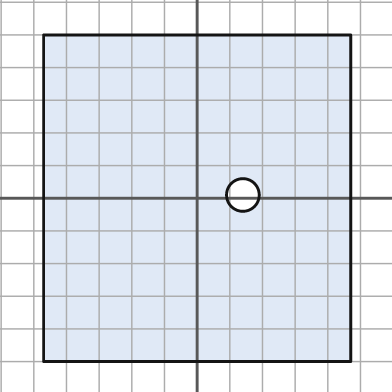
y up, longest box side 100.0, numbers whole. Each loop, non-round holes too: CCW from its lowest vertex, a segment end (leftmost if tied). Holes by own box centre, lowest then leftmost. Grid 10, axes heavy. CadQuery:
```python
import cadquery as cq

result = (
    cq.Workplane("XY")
    .moveTo(-47.0, -50.0)
    .lineTo(47.0, -50.0)
    .lineTo(47.0, 50.0)
    .lineTo(-47.0, 50.0)
    .close()
    .moveTo(14.0, 1.0)
    .circle(5.0)
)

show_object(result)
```